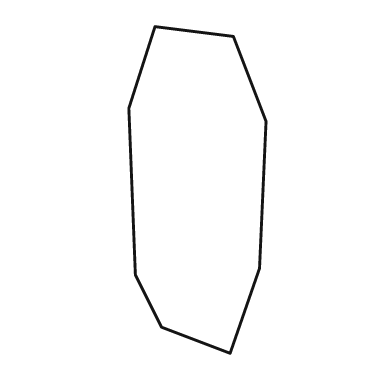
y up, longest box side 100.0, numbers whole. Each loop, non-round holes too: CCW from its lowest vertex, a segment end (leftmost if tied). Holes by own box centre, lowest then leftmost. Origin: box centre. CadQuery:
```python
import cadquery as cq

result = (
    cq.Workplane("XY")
    .moveTo(10.0, -50.0)
    .lineTo(19.0, -24.0)
    .lineTo(21.0, 21.0)
    .lineTo(11.0, 47.0)
    .lineTo(-13.0, 50.0)
    .lineTo(-21.0, 25.0)
    .lineTo(-19.0, -26.0)
    .lineTo(-11.0, -42.0)
    .close()
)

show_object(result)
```